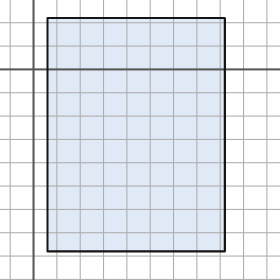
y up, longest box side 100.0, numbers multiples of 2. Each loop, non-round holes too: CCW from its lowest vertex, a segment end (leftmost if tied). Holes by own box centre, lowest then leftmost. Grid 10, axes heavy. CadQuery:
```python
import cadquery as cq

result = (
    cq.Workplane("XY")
    .moveTo(6.0, -78.0)
    .lineTo(82.0, -78.0)
    .lineTo(82.0, 22.0)
    .lineTo(6.0, 22.0)
    .close()
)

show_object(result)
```